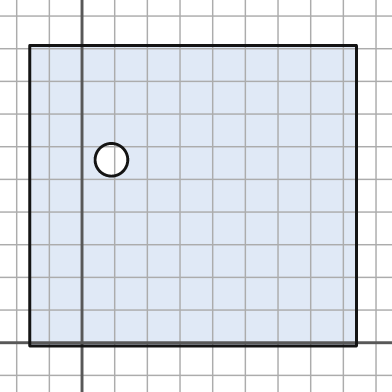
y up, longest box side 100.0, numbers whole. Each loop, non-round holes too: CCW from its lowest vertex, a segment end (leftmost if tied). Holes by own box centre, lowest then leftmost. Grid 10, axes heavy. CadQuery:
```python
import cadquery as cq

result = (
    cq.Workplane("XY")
    .moveTo(-16.0, -1.0)
    .lineTo(84.0, -1.0)
    .lineTo(84.0, 91.0)
    .lineTo(-16.0, 91.0)
    .close()
    .moveTo(9.0, 56.0)
    .circle(5.0)
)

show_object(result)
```